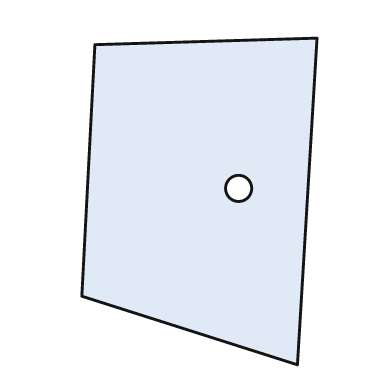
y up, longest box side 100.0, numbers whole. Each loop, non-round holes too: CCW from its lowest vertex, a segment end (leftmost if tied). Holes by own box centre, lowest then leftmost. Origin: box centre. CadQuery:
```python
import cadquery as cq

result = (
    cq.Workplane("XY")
    .moveTo(30.0, -50.0)
    .lineTo(36.0, 50.0)
    .lineTo(-32.0, 48.0)
    .lineTo(-36.0, -29.0)
    .close()
    .moveTo(12.0, 4.0)
    .circle(4.0)
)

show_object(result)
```